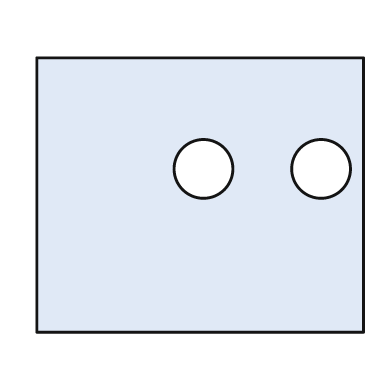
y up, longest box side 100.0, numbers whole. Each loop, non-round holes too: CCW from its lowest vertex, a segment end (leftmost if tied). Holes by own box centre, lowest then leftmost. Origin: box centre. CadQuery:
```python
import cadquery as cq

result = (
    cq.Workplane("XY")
    .moveTo(-50.0, -42.0)
    .lineTo(50.0, -42.0)
    .lineTo(50.0, 42.0)
    .lineTo(-50.0, 42.0)
    .close()
    .moveTo(1.0, 8.0)
    .circle(9.0)
    .moveTo(37.0, 8.0)
    .circle(9.0)
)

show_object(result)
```